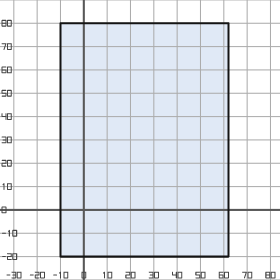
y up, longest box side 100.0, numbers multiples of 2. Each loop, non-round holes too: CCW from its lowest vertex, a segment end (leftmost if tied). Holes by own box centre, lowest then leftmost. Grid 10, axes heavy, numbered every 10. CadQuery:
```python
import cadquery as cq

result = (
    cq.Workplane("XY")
    .moveTo(-10.0, -20.0)
    .lineTo(62.0, -20.0)
    .lineTo(62.0, 80.0)
    .lineTo(-10.0, 80.0)
    .close()
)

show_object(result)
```